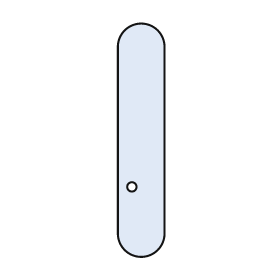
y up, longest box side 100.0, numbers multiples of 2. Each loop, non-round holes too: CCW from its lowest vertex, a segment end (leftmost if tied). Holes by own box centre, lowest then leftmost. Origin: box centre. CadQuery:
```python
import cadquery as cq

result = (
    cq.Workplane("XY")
    .moveTo(-10.0, -40.0)
    .threePointArc((0.0, -50.0), (10.0, -40.0))
    .lineTo(10.0, 40.0)
    .threePointArc((0.0, 50.0), (-10.0, 40.0))
    .close()
    .moveTo(-4.0, -20.0)
    .circle(2.0)
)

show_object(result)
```